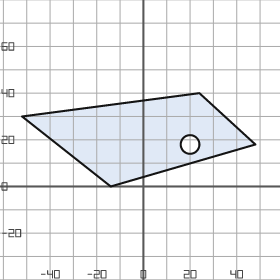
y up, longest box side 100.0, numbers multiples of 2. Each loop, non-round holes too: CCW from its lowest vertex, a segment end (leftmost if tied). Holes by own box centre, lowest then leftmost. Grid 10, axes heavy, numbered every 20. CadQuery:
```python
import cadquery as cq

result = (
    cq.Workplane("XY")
    .moveTo(-14.0, 0.0)
    .lineTo(48.0, 18.0)
    .lineTo(24.0, 40.0)
    .lineTo(-52.0, 30.0)
    .close()
    .moveTo(20.0, 18.0)
    .circle(4.0)
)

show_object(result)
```